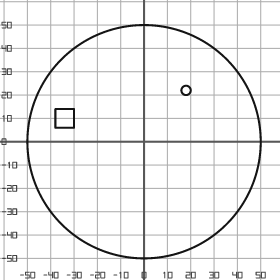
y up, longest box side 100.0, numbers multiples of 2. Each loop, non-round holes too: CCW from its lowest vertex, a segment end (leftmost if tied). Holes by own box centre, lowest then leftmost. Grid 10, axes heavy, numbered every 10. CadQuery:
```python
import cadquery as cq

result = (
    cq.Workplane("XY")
    .moveTo(0.0, 0.0)
    .circle(50.0)
    .moveTo(-38.0, 6.0)
    .lineTo(-30.0, 6.0)
    .lineTo(-30.0, 14.0)
    .lineTo(-38.0, 14.0)
    .close()
    .moveTo(18.0, 22.0)
    .circle(2.0)
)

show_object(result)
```